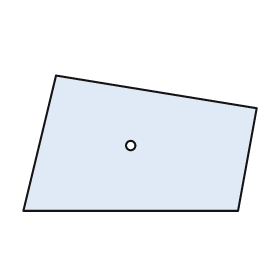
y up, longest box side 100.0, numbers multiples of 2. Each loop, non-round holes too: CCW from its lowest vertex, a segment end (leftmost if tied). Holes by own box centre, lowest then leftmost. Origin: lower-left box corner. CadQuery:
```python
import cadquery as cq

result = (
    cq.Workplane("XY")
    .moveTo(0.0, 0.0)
    .lineTo(92.0, 0.0)
    .lineTo(100.0, 44.0)
    .lineTo(14.0, 58.0)
    .close()
    .moveTo(46.0, 28.0)
    .circle(2.0)
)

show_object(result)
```